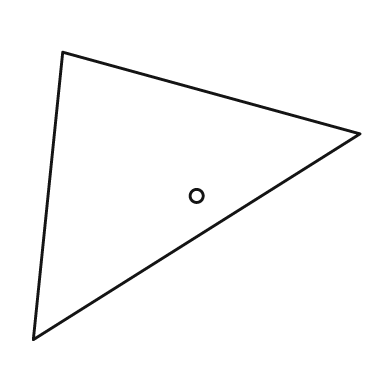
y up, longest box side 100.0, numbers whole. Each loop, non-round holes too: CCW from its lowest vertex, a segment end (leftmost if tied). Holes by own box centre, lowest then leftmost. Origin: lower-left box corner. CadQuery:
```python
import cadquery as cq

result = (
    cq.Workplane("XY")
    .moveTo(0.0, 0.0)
    .lineTo(100.0, 63.0)
    .lineTo(9.0, 88.0)
    .close()
    .moveTo(50.0, 44.0)
    .circle(2.0)
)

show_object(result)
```